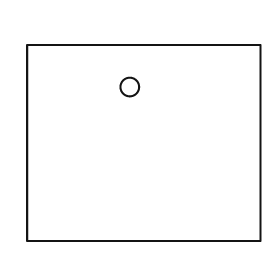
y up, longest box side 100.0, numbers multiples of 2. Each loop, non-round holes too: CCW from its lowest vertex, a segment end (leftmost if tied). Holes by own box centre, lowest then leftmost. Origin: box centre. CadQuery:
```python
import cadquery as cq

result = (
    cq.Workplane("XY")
    .moveTo(-50.0, -42.0)
    .lineTo(50.0, -42.0)
    .lineTo(50.0, 42.0)
    .lineTo(-50.0, 42.0)
    .close()
    .moveTo(-6.0, 24.0)
    .circle(4.0)
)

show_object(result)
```